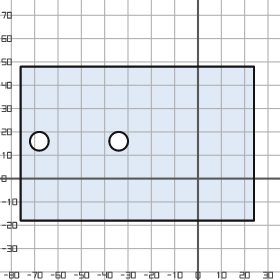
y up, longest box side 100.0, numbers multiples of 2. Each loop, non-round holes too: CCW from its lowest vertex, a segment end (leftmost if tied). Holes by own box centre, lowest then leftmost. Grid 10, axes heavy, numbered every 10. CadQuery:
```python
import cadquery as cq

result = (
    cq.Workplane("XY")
    .moveTo(-76.0, -18.0)
    .lineTo(24.0, -18.0)
    .lineTo(24.0, 48.0)
    .lineTo(-76.0, 48.0)
    .close()
    .moveTo(-68.0, 16.0)
    .circle(4.0)
    .moveTo(-34.0, 16.0)
    .circle(4.0)
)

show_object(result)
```